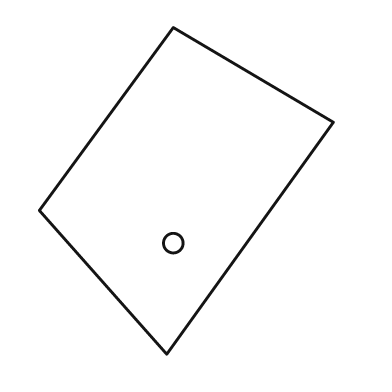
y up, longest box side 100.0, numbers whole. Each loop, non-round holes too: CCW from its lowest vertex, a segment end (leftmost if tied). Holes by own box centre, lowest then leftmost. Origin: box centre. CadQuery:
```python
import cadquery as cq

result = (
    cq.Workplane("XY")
    .moveTo(-6.0, -50.0)
    .lineTo(45.0, 21.0)
    .lineTo(-4.0, 50.0)
    .lineTo(-45.0, -6.0)
    .close()
    .moveTo(-4.0, -16.0)
    .circle(3.0)
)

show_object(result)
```